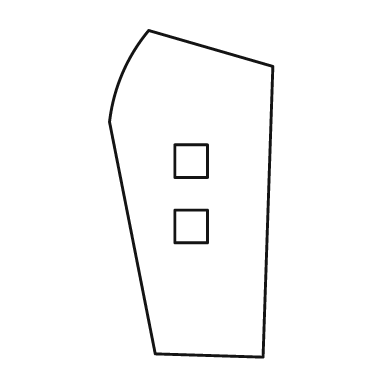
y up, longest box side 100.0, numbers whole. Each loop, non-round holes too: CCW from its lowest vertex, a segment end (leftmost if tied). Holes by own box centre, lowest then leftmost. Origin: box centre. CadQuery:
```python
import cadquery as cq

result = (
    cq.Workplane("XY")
    .moveTo(22.0, -50.0)
    .lineTo(25.0, 39.0)
    .lineTo(-13.0, 50.0)
    .threePointArc((-21.0, 37.0), (-25.0, 22.0))
    .lineTo(-11.0, -49.0)
    .close()
    .moveTo(-5.0, -15.0)
    .lineTo(5.0, -15.0)
    .lineTo(5.0, -5.0)
    .lineTo(-5.0, -5.0)
    .close()
    .moveTo(-5.0, 5.0)
    .lineTo(5.0, 5.0)
    .lineTo(5.0, 15.0)
    .lineTo(-5.0, 15.0)
    .close()
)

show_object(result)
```